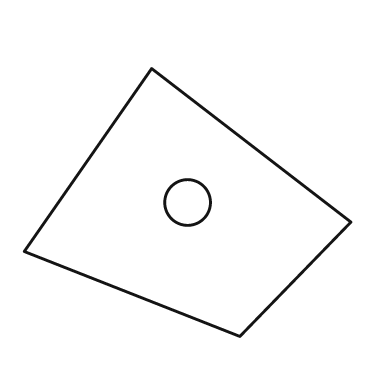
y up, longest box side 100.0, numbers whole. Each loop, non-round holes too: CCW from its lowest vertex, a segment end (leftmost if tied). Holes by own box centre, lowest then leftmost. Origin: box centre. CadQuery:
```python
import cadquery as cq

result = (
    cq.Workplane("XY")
    .moveTo(16.0, -41.0)
    .lineTo(50.0, -6.0)
    .lineTo(-11.0, 41.0)
    .lineTo(-50.0, -15.0)
    .close()
    .moveTo(0.0, 0.0)
    .circle(7.0)
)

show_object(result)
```